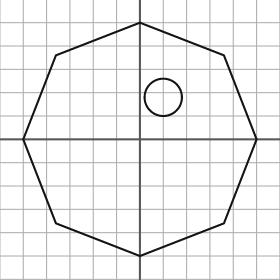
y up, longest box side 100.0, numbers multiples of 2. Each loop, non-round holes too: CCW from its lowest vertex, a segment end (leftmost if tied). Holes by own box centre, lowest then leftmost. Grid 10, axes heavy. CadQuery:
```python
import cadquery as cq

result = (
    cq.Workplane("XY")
    .moveTo(0.0, -50.0)
    .lineTo(36.0, -36.0)
    .lineTo(50.0, 0.0)
    .lineTo(36.0, 36.0)
    .lineTo(0.0, 50.0)
    .lineTo(-36.0, 36.0)
    .lineTo(-50.0, 0.0)
    .lineTo(-36.0, -36.0)
    .close()
    .moveTo(10.0, 18.0)
    .circle(8.0)
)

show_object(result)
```